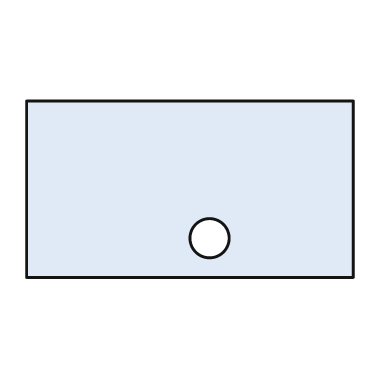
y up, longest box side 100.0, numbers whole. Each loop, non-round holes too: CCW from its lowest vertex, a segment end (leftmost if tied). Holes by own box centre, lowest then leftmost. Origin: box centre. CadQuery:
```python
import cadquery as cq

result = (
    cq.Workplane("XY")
    .moveTo(-50.0, -27.0)
    .lineTo(50.0, -27.0)
    .lineTo(50.0, 27.0)
    .lineTo(-50.0, 27.0)
    .close()
    .moveTo(6.0, -15.0)
    .circle(6.0)
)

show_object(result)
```